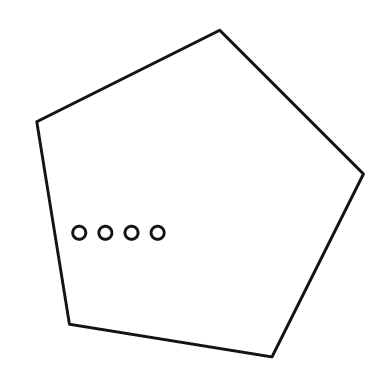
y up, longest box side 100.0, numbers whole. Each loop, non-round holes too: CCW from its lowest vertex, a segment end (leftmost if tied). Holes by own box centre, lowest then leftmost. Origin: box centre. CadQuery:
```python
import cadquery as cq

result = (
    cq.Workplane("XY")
    .moveTo(22.0, -50.0)
    .lineTo(50.0, 6.0)
    .lineTo(6.0, 50.0)
    .lineTo(-50.0, 22.0)
    .lineTo(-40.0, -40.0)
    .close()
    .moveTo(-37.0, -12.0)
    .circle(2.0)
    .moveTo(-29.0, -12.0)
    .circle(2.0)
    .moveTo(-21.0, -12.0)
    .circle(2.0)
    .moveTo(-13.0, -12.0)
    .circle(2.0)
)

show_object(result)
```